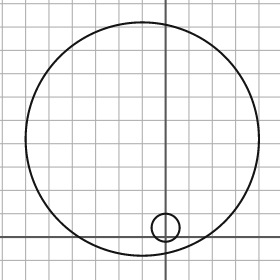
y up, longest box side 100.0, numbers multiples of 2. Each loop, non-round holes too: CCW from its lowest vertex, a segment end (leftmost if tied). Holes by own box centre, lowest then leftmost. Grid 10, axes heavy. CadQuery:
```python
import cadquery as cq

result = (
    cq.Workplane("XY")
    .moveTo(-10.0, 42.0)
    .circle(50.0)
    .moveTo(0.0, 4.0)
    .circle(6.0)
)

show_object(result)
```